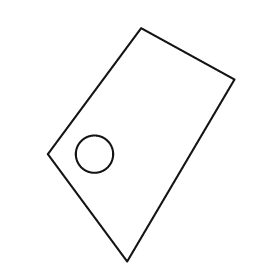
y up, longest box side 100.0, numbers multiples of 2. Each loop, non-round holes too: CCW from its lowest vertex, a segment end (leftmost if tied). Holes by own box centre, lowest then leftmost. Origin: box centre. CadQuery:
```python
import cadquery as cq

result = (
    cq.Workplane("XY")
    .moveTo(-6.0, -50.0)
    .lineTo(40.0, 28.0)
    .lineTo(0.0, 50.0)
    .lineTo(-40.0, -4.0)
    .close()
    .moveTo(-20.0, -4.0)
    .circle(8.0)
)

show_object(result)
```